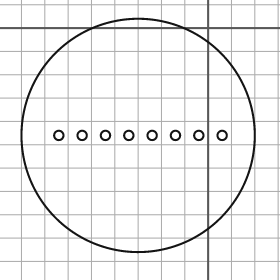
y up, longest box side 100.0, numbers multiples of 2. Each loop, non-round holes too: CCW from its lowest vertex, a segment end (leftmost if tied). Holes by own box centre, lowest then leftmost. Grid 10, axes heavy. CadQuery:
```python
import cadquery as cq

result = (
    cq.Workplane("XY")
    .moveTo(-30.0, -46.0)
    .circle(50.0)
    .moveTo(-64.0, -46.0)
    .circle(2.0)
    .moveTo(-54.0, -46.0)
    .circle(2.0)
    .moveTo(-44.0, -46.0)
    .circle(2.0)
    .moveTo(-34.0, -46.0)
    .circle(2.0)
    .moveTo(-24.0, -46.0)
    .circle(2.0)
    .moveTo(-14.0, -46.0)
    .circle(2.0)
    .moveTo(-4.0, -46.0)
    .circle(2.0)
    .moveTo(6.0, -46.0)
    .circle(2.0)
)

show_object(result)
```